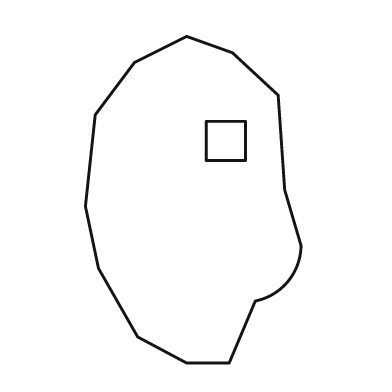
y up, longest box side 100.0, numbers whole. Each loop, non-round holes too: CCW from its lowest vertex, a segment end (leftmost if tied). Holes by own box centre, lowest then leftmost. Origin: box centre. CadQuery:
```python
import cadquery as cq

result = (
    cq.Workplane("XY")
    .moveTo(-2.0, -50.0)
    .lineTo(11.0, -50.0)
    .lineTo(19.0, -31.0)
    .threePointArc((29.0, -25.0), (33.0, -14.0))
    .lineTo(28.0, 3.0)
    .lineTo(26.0, 32.0)
    .lineTo(12.0, 45.0)
    .lineTo(-2.0, 50.0)
    .lineTo(-18.0, 42.0)
    .lineTo(-30.0, 26.0)
    .lineTo(-33.0, -2.0)
    .lineTo(-29.0, -21.0)
    .lineTo(-17.0, -42.0)
    .close()
    .moveTo(4.0, 12.0)
    .lineTo(16.0, 12.0)
    .lineTo(16.0, 24.0)
    .lineTo(4.0, 24.0)
    .close()
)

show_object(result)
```